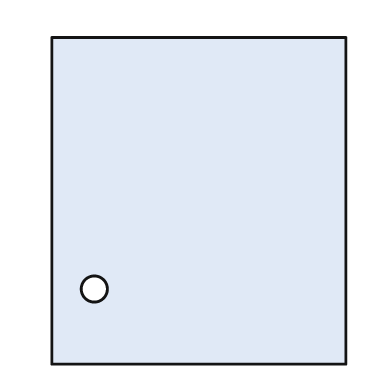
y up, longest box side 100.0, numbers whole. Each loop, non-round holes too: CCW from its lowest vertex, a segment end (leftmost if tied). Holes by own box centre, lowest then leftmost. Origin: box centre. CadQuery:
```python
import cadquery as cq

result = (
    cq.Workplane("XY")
    .moveTo(-45.0, -50.0)
    .lineTo(45.0, -50.0)
    .lineTo(45.0, 50.0)
    .lineTo(-45.0, 50.0)
    .close()
    .moveTo(-32.0, -27.0)
    .circle(4.0)
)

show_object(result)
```